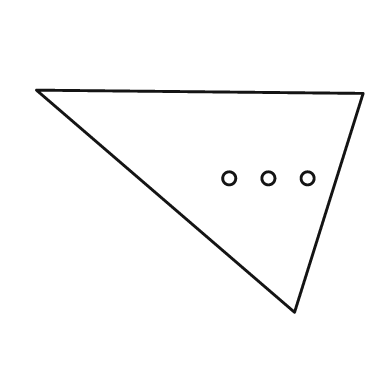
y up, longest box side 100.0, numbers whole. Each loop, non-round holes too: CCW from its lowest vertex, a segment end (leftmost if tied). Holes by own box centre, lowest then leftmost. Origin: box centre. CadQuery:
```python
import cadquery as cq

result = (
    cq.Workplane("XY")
    .moveTo(29.0, -34.0)
    .lineTo(50.0, 33.0)
    .lineTo(-50.0, 34.0)
    .close()
    .moveTo(9.0, 7.0)
    .circle(2.0)
    .moveTo(21.0, 7.0)
    .circle(2.0)
    .moveTo(33.0, 7.0)
    .circle(2.0)
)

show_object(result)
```